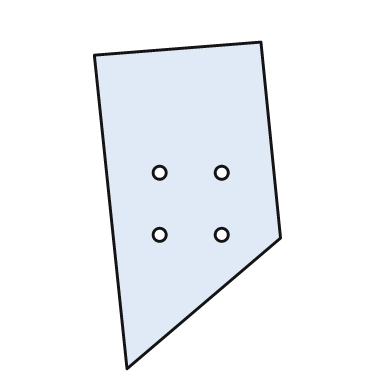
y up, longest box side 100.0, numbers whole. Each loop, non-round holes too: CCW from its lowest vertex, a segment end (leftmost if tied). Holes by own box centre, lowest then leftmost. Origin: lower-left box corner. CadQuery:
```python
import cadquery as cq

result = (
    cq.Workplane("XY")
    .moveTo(10.0, 0.0)
    .lineTo(57.0, 40.0)
    .lineTo(51.0, 100.0)
    .lineTo(0.0, 96.0)
    .close()
    .moveTo(20.0, 41.0)
    .circle(2.0)
    .moveTo(39.0, 41.0)
    .circle(2.0)
    .moveTo(20.0, 60.0)
    .circle(2.0)
    .moveTo(39.0, 60.0)
    .circle(2.0)
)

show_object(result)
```